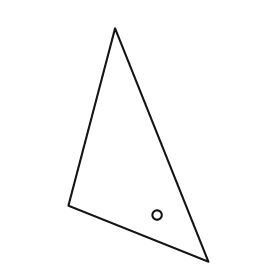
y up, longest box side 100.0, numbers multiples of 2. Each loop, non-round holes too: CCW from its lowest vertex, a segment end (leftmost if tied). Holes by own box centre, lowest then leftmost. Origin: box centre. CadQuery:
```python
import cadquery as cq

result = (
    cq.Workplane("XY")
    .moveTo(30.0, -50.0)
    .lineTo(-10.0, 50.0)
    .lineTo(-30.0, -26.0)
    .close()
    .moveTo(8.0, -30.0)
    .circle(2.0)
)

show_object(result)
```